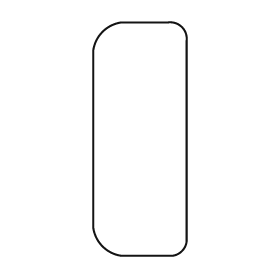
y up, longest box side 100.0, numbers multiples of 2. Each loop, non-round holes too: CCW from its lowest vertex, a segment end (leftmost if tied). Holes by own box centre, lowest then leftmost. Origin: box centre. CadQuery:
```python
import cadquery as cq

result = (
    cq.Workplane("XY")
    .moveTo(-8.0, -50.0)
    .lineTo(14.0, -50.0)
    .threePointArc((18.0, -48.0), (20.0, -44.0))
    .lineTo(20.0, 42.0)
    .threePointArc((18.0, 48.0), (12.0, 50.0))
    .lineTo(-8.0, 50.0)
    .threePointArc((-16.0, 46.0), (-20.0, 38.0))
    .lineTo(-20.0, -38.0)
    .threePointArc((-16.0, -46.0), (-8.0, -50.0))
    .close()
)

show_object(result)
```